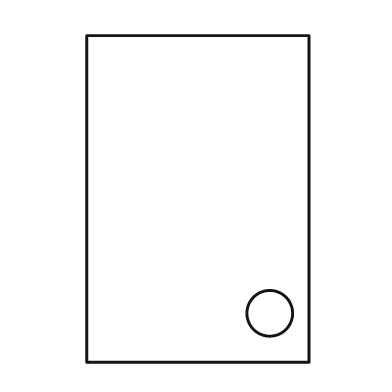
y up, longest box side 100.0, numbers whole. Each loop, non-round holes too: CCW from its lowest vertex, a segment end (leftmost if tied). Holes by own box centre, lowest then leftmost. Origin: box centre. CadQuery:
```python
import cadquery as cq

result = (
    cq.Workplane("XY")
    .moveTo(-34.0, -50.0)
    .lineTo(34.0, -50.0)
    .lineTo(34.0, 50.0)
    .lineTo(-34.0, 50.0)
    .close()
    .moveTo(22.0, -35.0)
    .circle(7.0)
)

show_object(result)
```